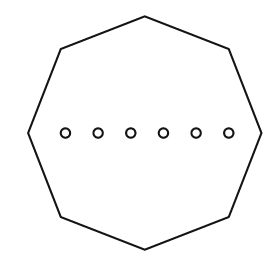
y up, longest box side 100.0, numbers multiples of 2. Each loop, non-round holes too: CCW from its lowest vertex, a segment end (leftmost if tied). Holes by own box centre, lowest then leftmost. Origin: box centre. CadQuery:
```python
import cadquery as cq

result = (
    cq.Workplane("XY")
    .moveTo(0.0, -50.0)
    .lineTo(36.0, -36.0)
    .lineTo(50.0, 0.0)
    .lineTo(36.0, 36.0)
    .lineTo(0.0, 50.0)
    .lineTo(-36.0, 36.0)
    .lineTo(-50.0, 0.0)
    .lineTo(-36.0, -36.0)
    .close()
    .moveTo(-34.0, 0.0)
    .circle(2.0)
    .moveTo(-20.0, 0.0)
    .circle(2.0)
    .moveTo(-6.0, 0.0)
    .circle(2.0)
    .moveTo(8.0, 0.0)
    .circle(2.0)
    .moveTo(22.0, 0.0)
    .circle(2.0)
    .moveTo(36.0, 0.0)
    .circle(2.0)
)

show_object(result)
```